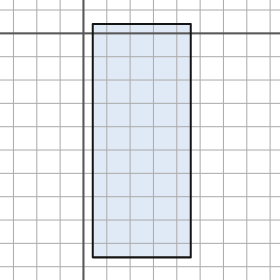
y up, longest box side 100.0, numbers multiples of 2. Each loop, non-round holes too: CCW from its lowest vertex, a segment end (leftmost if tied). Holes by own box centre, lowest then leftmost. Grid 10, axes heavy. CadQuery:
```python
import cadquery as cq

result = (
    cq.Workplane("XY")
    .moveTo(4.0, -96.0)
    .lineTo(46.0, -96.0)
    .lineTo(46.0, 4.0)
    .lineTo(4.0, 4.0)
    .close()
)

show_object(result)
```